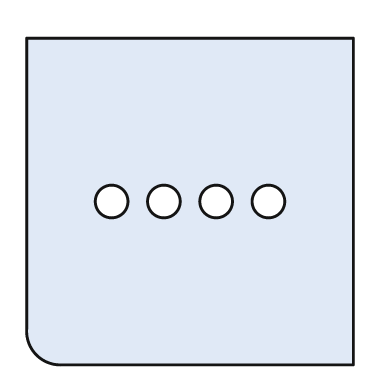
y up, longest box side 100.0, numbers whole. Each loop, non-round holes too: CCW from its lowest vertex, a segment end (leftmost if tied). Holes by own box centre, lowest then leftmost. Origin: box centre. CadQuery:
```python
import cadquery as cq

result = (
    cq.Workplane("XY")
    .moveTo(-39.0, -50.0)
    .lineTo(50.0, -50.0)
    .lineTo(50.0, 50.0)
    .lineTo(-50.0, 50.0)
    .lineTo(-50.0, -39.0)
    .threePointArc((-47.0, -47.0), (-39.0, -50.0))
    .close()
    .moveTo(-24.0, 0.0)
    .circle(5.0)
    .moveTo(-8.0, 0.0)
    .circle(5.0)
    .moveTo(8.0, 0.0)
    .circle(5.0)
    .moveTo(24.0, 0.0)
    .circle(5.0)
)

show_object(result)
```